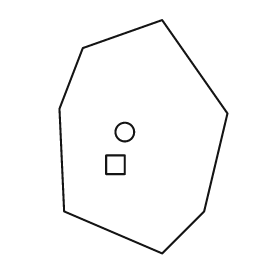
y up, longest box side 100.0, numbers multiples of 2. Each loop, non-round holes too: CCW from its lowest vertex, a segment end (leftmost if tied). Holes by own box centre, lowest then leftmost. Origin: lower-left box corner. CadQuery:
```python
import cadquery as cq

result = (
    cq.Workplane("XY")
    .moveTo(44.0, 0.0)
    .lineTo(62.0, 18.0)
    .lineTo(72.0, 60.0)
    .lineTo(44.0, 100.0)
    .lineTo(10.0, 88.0)
    .lineTo(0.0, 62.0)
    .lineTo(2.0, 18.0)
    .close()
    .moveTo(20.0, 34.0)
    .lineTo(28.0, 34.0)
    .lineTo(28.0, 42.0)
    .lineTo(20.0, 42.0)
    .close()
    .moveTo(28.0, 52.0)
    .circle(4.0)
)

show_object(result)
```